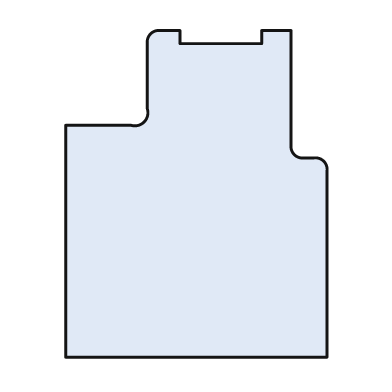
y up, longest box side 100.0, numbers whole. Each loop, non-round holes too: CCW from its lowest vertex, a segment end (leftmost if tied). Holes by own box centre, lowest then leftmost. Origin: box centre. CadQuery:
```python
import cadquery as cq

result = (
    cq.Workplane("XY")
    .moveTo(-40.0, -50.0)
    .lineTo(40.0, -50.0)
    .lineTo(40.0, 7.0)
    .threePointArc((39.0, 10.0), (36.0, 11.0))
    .lineTo(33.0, 11.0)
    .threePointArc((30.0, 12.0), (29.0, 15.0))
    .lineTo(29.0, 50.0)
    .lineTo(20.0, 50.0)
    .lineTo(20.0, 46.0)
    .lineTo(-5.0, 46.0)
    .lineTo(-5.0, 50.0)
    .lineTo(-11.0, 50.0)
    .threePointArc((-14.0, 49.0), (-15.0, 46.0))
    .lineTo(-15.0, 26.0)
    .threePointArc((-16.0, 22.0), (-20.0, 21.0))
    .lineTo(-40.0, 21.0)
    .close()
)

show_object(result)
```